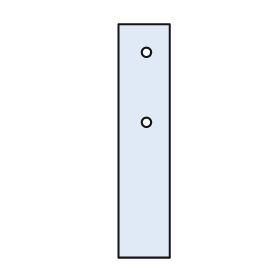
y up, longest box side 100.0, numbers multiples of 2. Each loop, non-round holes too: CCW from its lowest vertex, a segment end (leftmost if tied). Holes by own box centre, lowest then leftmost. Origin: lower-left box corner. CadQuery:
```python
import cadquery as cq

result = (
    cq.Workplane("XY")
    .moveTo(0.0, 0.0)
    .lineTo(22.0, 0.0)
    .lineTo(22.0, 100.0)
    .lineTo(0.0, 100.0)
    .close()
    .moveTo(12.0, 58.0)
    .circle(2.0)
    .moveTo(12.0, 88.0)
    .circle(2.0)
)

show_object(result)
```